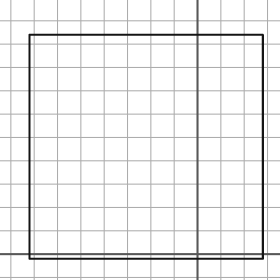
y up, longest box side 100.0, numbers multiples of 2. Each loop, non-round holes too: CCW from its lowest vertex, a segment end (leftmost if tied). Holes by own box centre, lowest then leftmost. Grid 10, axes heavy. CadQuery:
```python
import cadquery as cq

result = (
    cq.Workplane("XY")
    .moveTo(-72.0, -2.0)
    .lineTo(28.0, -2.0)
    .lineTo(28.0, 94.0)
    .lineTo(-72.0, 94.0)
    .close()
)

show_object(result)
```